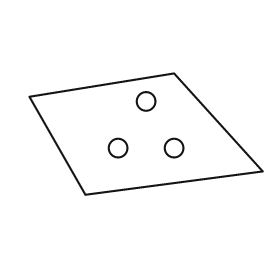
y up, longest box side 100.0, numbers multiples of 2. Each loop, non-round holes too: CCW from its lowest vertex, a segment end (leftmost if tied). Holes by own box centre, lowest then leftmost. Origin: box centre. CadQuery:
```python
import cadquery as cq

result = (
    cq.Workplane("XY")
    .moveTo(-26.0, -26.0)
    .lineTo(50.0, -16.0)
    .lineTo(12.0, 26.0)
    .lineTo(-50.0, 16.0)
    .close()
    .moveTo(-12.0, -6.0)
    .circle(4.0)
    .moveTo(12.0, -6.0)
    .circle(4.0)
    .moveTo(0.0, 14.0)
    .circle(4.0)
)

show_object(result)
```